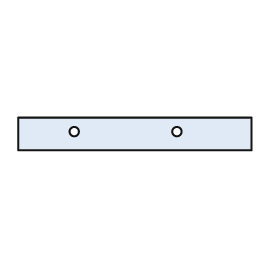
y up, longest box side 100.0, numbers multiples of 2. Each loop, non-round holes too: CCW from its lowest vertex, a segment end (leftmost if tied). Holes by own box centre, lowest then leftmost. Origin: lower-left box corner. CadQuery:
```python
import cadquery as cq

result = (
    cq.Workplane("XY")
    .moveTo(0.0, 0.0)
    .lineTo(100.0, 0.0)
    .lineTo(100.0, 14.0)
    .lineTo(0.0, 14.0)
    .close()
    .moveTo(24.0, 8.0)
    .circle(2.0)
    .moveTo(68.0, 8.0)
    .circle(2.0)
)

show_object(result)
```